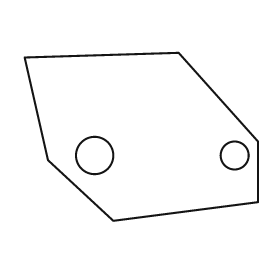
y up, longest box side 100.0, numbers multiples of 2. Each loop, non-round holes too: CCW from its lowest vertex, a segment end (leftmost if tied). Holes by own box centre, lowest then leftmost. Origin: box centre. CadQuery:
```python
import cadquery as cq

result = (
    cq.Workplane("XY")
    .moveTo(-12.0, -36.0)
    .lineTo(50.0, -28.0)
    .lineTo(50.0, -2.0)
    .lineTo(16.0, 36.0)
    .lineTo(-50.0, 34.0)
    .lineTo(-40.0, -10.0)
    .close()
    .moveTo(-20.0, -8.0)
    .circle(8.0)
    .moveTo(40.0, -8.0)
    .circle(6.0)
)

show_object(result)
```